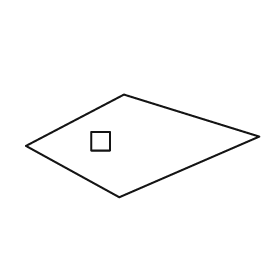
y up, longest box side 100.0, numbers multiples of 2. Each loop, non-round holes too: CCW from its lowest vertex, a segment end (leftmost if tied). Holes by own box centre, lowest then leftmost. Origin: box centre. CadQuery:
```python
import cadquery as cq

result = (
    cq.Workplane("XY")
    .moveTo(-10.0, -22.0)
    .lineTo(50.0, 4.0)
    .lineTo(-8.0, 22.0)
    .lineTo(-50.0, 0.0)
    .close()
    .moveTo(-22.0, -2.0)
    .lineTo(-14.0, -2.0)
    .lineTo(-14.0, 6.0)
    .lineTo(-22.0, 6.0)
    .close()
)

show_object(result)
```